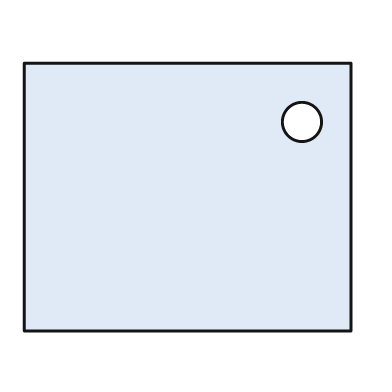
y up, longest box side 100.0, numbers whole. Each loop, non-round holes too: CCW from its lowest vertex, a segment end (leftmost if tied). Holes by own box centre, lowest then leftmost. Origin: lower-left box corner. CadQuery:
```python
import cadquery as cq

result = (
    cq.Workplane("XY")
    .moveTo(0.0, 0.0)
    .lineTo(100.0, 0.0)
    .lineTo(100.0, 82.0)
    .lineTo(0.0, 82.0)
    .close()
    .moveTo(85.0, 64.0)
    .circle(6.0)
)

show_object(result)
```